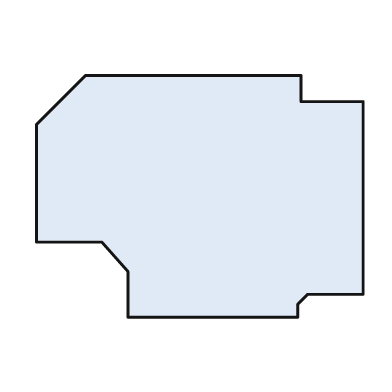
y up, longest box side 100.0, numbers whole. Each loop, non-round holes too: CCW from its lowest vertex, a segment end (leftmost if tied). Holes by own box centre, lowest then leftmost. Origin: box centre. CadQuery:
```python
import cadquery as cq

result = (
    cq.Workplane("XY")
    .moveTo(-22.0, -37.0)
    .lineTo(30.0, -37.0)
    .lineTo(30.0, -33.0)
    .lineTo(33.0, -30.0)
    .lineTo(50.0, -30.0)
    .lineTo(50.0, 29.0)
    .lineTo(31.0, 29.0)
    .lineTo(31.0, 37.0)
    .lineTo(-35.0, 37.0)
    .lineTo(-50.0, 22.0)
    .lineTo(-50.0, -14.0)
    .lineTo(-30.0, -14.0)
    .lineTo(-22.0, -23.0)
    .close()
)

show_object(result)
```